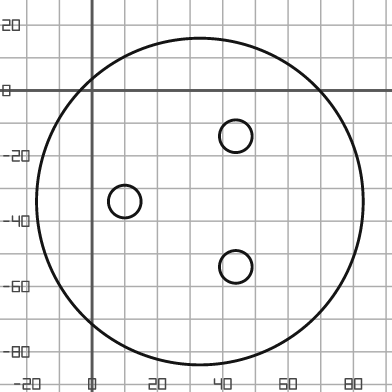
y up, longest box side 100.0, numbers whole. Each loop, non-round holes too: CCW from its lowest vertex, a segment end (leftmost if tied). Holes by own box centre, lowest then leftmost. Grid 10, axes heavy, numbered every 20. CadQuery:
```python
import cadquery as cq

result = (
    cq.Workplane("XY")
    .moveTo(33.0, -34.0)
    .circle(50.0)
    .moveTo(44.0, -54.0)
    .circle(5.0)
    .moveTo(10.0, -34.0)
    .circle(5.0)
    .moveTo(44.0, -14.0)
    .circle(5.0)
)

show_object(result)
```